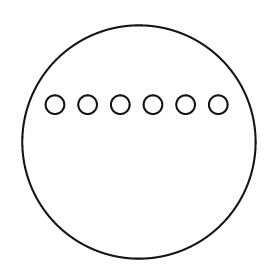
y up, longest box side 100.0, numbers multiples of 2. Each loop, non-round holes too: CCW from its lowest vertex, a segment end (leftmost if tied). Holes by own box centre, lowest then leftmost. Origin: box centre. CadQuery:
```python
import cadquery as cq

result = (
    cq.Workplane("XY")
    .moveTo(0.0, 0.0)
    .circle(50.0)
    .moveTo(-36.0, 16.0)
    .circle(4.0)
    .moveTo(-22.0, 16.0)
    .circle(4.0)
    .moveTo(-8.0, 16.0)
    .circle(4.0)
    .moveTo(6.0, 16.0)
    .circle(4.0)
    .moveTo(20.0, 16.0)
    .circle(4.0)
    .moveTo(34.0, 16.0)
    .circle(4.0)
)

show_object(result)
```